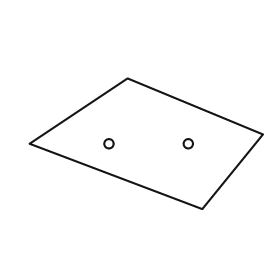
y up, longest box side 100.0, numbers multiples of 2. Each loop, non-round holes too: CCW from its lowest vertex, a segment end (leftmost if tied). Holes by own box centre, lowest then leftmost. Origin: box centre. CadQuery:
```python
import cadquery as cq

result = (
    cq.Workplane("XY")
    .moveTo(24.0, -28.0)
    .lineTo(50.0, 4.0)
    .lineTo(-8.0, 28.0)
    .lineTo(-50.0, 0.0)
    .close()
    .moveTo(-16.0, 0.0)
    .circle(2.0)
    .moveTo(18.0, 0.0)
    .circle(2.0)
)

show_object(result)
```